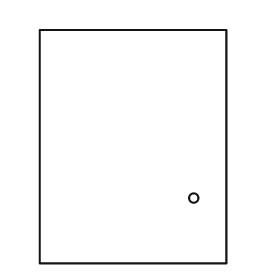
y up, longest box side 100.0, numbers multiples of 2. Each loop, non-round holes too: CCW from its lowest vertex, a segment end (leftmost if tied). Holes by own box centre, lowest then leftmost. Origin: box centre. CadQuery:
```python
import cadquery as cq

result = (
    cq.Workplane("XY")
    .moveTo(-40.0, -50.0)
    .lineTo(40.0, -50.0)
    .lineTo(40.0, 50.0)
    .lineTo(-40.0, 50.0)
    .close()
    .moveTo(26.0, -22.0)
    .circle(2.0)
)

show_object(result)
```